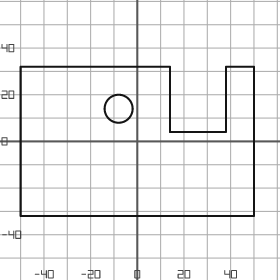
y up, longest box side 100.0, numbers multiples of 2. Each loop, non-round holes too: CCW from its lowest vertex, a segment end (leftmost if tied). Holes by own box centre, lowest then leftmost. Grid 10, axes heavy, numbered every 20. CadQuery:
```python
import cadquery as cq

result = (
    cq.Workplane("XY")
    .moveTo(-50.0, -32.0)
    .lineTo(50.0, -32.0)
    .lineTo(50.0, 32.0)
    .lineTo(38.0, 32.0)
    .lineTo(38.0, 4.0)
    .lineTo(14.0, 4.0)
    .lineTo(14.0, 32.0)
    .lineTo(-50.0, 32.0)
    .close()
    .moveTo(-8.0, 14.0)
    .circle(6.0)
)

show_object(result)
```